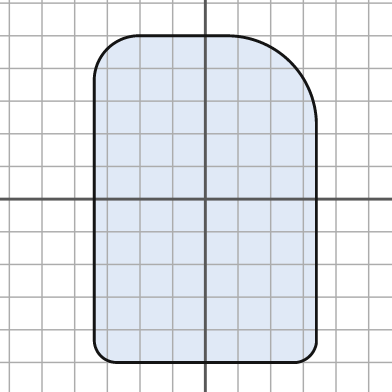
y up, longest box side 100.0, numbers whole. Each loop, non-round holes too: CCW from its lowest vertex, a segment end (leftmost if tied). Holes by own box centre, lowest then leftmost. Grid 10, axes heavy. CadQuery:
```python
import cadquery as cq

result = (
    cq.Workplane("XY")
    .moveTo(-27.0, -50.0)
    .lineTo(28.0, -50.0)
    .threePointArc((32.0, -48.0), (34.0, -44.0))
    .lineTo(34.0, 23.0)
    .threePointArc((26.0, 42.0), (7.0, 50.0))
    .lineTo(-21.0, 50.0)
    .threePointArc((-30.0, 46.0), (-34.0, 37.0))
    .lineTo(-34.0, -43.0)
    .threePointArc((-32.0, -48.0), (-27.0, -50.0))
    .close()
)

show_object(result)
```